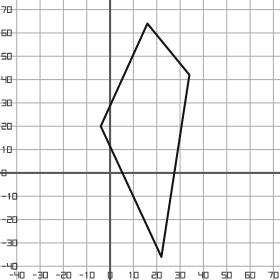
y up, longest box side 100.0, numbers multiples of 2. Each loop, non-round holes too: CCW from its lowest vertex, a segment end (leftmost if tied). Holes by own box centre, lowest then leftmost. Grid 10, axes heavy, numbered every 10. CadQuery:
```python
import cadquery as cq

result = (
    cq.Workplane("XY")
    .moveTo(22.0, -36.0)
    .lineTo(34.0, 42.0)
    .lineTo(16.0, 64.0)
    .lineTo(-4.0, 20.0)
    .close()
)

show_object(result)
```